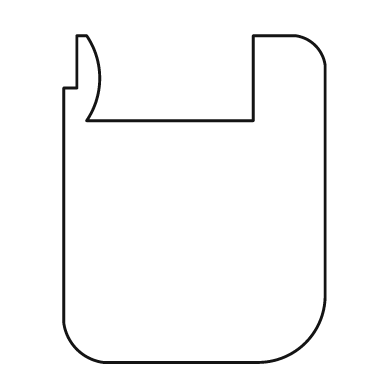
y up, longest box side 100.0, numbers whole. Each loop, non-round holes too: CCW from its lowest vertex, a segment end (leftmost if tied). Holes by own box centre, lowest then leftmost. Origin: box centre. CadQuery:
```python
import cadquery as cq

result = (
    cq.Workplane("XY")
    .moveTo(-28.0, -50.0)
    .lineTo(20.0, -50.0)
    .threePointArc((34.0, -44.0), (40.0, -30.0))
    .lineTo(40.0, 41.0)
    .threePointArc((37.0, 47.0), (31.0, 50.0))
    .lineTo(18.0, 50.0)
    .lineTo(18.0, 24.0)
    .lineTo(-33.0, 24.0)
    .threePointArc((-29.0, 37.0), (-33.0, 50.0))
    .lineTo(-36.0, 50.0)
    .lineTo(-36.0, 34.0)
    .lineTo(-40.0, 34.0)
    .lineTo(-40.0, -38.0)
    .threePointArc((-36.0, -46.0), (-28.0, -50.0))
    .close()
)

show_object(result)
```